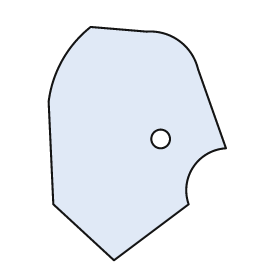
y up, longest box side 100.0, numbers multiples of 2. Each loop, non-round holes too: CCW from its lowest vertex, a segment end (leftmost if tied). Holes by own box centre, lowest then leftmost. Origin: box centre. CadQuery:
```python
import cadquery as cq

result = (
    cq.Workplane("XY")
    .moveTo(-10.0, -50.0)
    .lineTo(22.0, -26.0)
    .threePointArc((24.0, -10.0), (38.0, -2.0))
    .lineTo(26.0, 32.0)
    .threePointArc((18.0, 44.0), (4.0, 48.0))
    .lineTo(-20.0, 50.0)
    .threePointArc((-32.0, 36.0), (-38.0, 18.0))
    .lineTo(-36.0, -26.0)
    .close()
    .moveTo(10.0, 2.0)
    .circle(4.0)
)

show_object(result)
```